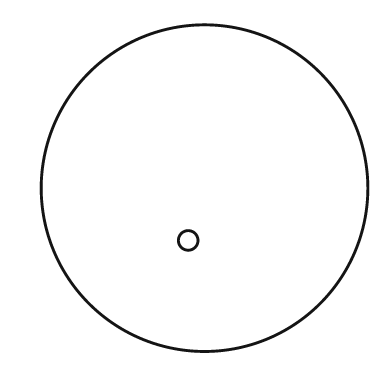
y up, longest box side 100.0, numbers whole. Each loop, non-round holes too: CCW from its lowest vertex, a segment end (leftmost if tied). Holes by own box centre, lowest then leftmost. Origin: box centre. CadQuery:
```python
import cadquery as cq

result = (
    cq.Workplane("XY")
    .moveTo(0.0, 0.0)
    .circle(50.0)
    .moveTo(-5.0, -16.0)
    .circle(3.0)
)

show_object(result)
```